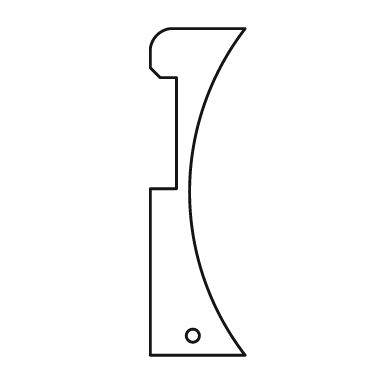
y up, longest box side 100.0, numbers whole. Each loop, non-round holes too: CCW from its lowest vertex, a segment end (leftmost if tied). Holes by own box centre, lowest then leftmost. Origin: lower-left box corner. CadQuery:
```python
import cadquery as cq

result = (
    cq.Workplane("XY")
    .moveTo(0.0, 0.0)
    .lineTo(29.0, 0.0)
    .threePointArc((12.0, 50.0), (29.0, 100.0))
    .lineTo(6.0, 100.0)
    .threePointArc((2.0, 98.0), (0.0, 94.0))
    .lineTo(0.0, 88.0)
    .lineTo(3.0, 85.0)
    .lineTo(8.0, 85.0)
    .lineTo(8.0, 51.0)
    .lineTo(0.0, 51.0)
    .close()
    .moveTo(13.0, 6.0)
    .circle(2.0)
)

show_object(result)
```